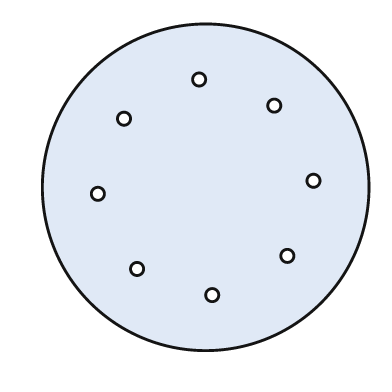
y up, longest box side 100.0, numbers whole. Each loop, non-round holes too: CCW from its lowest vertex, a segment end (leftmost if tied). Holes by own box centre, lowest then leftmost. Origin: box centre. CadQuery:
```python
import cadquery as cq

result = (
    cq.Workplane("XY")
    .moveTo(0.0, 0.0)
    .circle(50.0)
    .moveTo(2.0, -33.0)
    .circle(2.0)
    .moveTo(-21.0, -25.0)
    .circle(2.0)
    .moveTo(25.0, -21.0)
    .circle(2.0)
    .moveTo(-33.0, -2.0)
    .circle(2.0)
    .moveTo(33.0, 2.0)
    .circle(2.0)
    .moveTo(-25.0, 21.0)
    .circle(2.0)
    .moveTo(21.0, 25.0)
    .circle(2.0)
    .moveTo(-2.0, 33.0)
    .circle(2.0)
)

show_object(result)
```